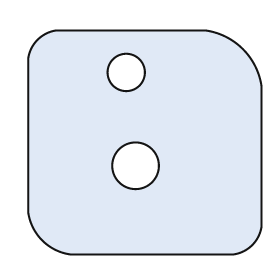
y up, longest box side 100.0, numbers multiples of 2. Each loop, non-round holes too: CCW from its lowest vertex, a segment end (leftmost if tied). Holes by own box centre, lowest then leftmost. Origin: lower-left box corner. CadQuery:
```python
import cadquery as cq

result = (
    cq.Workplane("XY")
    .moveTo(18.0, 0.0)
    .lineTo(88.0, 0.0)
    .threePointArc((96.0, 4.0), (100.0, 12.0))
    .lineTo(100.0, 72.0)
    .threePointArc((92.0, 88.0), (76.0, 96.0))
    .lineTo(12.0, 96.0)
    .threePointArc((4.0, 92.0), (0.0, 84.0))
    .lineTo(0.0, 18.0)
    .threePointArc((6.0, 6.0), (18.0, 0.0))
    .close()
    .moveTo(46.0, 38.0)
    .circle(10.0)
    .moveTo(42.0, 78.0)
    .circle(8.0)
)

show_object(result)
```